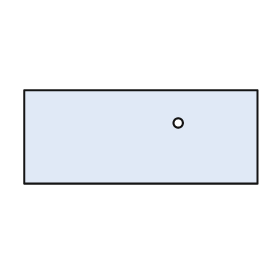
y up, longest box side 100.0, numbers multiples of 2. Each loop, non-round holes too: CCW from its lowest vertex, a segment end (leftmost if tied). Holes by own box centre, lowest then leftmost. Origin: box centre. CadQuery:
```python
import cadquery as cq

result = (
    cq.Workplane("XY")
    .moveTo(-50.0, -20.0)
    .lineTo(50.0, -20.0)
    .lineTo(50.0, 20.0)
    .lineTo(-50.0, 20.0)
    .close()
    .moveTo(16.0, 6.0)
    .circle(2.0)
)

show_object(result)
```